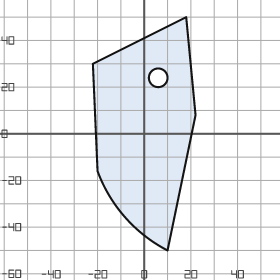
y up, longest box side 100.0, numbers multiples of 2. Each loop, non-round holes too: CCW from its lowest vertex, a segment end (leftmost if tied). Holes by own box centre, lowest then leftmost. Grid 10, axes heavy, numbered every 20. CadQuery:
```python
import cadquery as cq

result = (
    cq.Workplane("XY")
    .moveTo(10.0, -50.0)
    .lineTo(22.0, 8.0)
    .lineTo(18.0, 50.0)
    .lineTo(-22.0, 30.0)
    .lineTo(-20.0, -16.0)
    .threePointArc((-8.0, -36.0), (10.0, -50.0))
    .close()
    .moveTo(6.0, 24.0)
    .circle(4.0)
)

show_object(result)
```